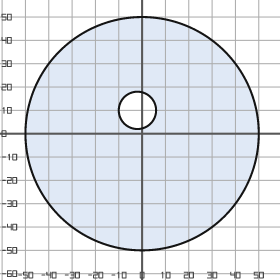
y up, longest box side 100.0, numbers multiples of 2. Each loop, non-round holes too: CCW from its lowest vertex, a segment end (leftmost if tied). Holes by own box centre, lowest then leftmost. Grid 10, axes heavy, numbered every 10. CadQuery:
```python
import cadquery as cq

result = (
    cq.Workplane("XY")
    .moveTo(0.0, 0.0)
    .circle(50.0)
    .moveTo(-2.0, 10.0)
    .circle(8.0)
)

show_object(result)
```